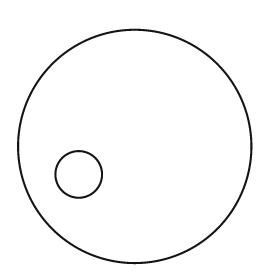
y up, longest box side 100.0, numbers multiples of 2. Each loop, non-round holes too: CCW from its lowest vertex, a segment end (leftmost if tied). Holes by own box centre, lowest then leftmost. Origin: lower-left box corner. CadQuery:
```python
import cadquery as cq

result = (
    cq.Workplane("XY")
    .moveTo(50.0, 50.0)
    .circle(50.0)
    .moveTo(26.0, 38.0)
    .circle(10.0)
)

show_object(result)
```